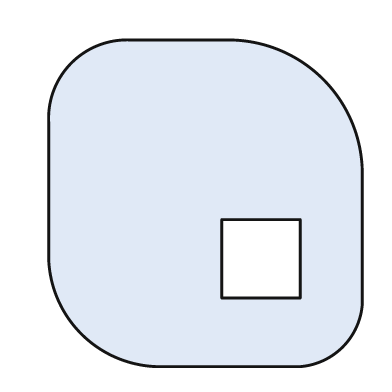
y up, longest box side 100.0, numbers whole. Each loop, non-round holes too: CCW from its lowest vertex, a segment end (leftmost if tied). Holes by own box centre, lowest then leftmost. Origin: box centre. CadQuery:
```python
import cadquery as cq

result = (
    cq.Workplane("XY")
    .moveTo(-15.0, -50.0)
    .lineTo(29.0, -50.0)
    .threePointArc((42.0, -44.0), (48.0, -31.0))
    .lineTo(48.0, 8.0)
    .threePointArc((36.0, 38.0), (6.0, 50.0))
    .lineTo(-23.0, 50.0)
    .threePointArc((-41.0, 43.0), (-48.0, 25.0))
    .lineTo(-48.0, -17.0)
    .threePointArc((-38.0, -40.0), (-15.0, -50.0))
    .close()
    .moveTo(5.0, -29.0)
    .lineTo(29.0, -29.0)
    .lineTo(29.0, -5.0)
    .lineTo(5.0, -5.0)
    .close()
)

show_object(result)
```